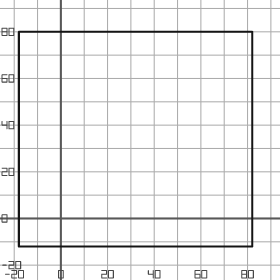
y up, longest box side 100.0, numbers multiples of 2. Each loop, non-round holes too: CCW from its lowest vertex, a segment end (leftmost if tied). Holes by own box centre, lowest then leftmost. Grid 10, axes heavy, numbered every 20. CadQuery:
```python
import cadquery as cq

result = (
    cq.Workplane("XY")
    .moveTo(-18.0, -12.0)
    .lineTo(82.0, -12.0)
    .lineTo(82.0, 80.0)
    .lineTo(-18.0, 80.0)
    .close()
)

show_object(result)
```